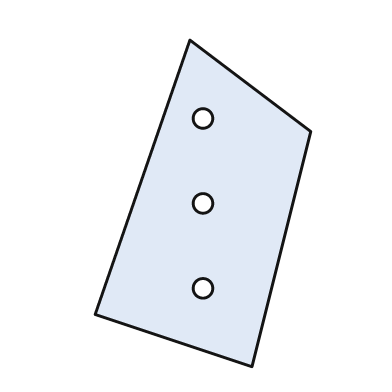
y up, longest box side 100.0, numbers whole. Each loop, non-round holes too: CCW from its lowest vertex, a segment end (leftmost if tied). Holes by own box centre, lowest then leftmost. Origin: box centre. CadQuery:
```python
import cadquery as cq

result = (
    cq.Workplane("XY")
    .moveTo(15.0, -50.0)
    .lineTo(33.0, 22.0)
    .lineTo(-4.0, 50.0)
    .lineTo(-33.0, -34.0)
    .close()
    .moveTo(0.0, -26.0)
    .circle(3.0)
    .moveTo(0.0, 0.0)
    .circle(3.0)
    .moveTo(0.0, 26.0)
    .circle(3.0)
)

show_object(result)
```